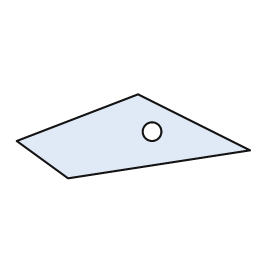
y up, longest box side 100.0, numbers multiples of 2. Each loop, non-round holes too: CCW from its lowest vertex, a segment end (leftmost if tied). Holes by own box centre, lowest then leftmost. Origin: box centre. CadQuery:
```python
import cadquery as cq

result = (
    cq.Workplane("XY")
    .moveTo(-28.0, -18.0)
    .lineTo(50.0, -6.0)
    .lineTo(2.0, 18.0)
    .lineTo(-50.0, -2.0)
    .close()
    .moveTo(8.0, 2.0)
    .circle(4.0)
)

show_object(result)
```